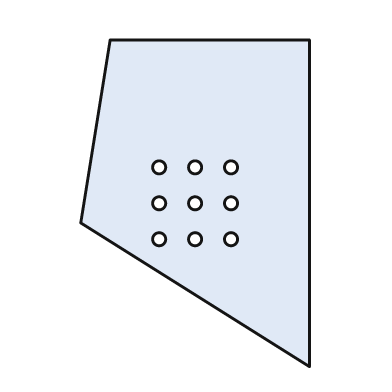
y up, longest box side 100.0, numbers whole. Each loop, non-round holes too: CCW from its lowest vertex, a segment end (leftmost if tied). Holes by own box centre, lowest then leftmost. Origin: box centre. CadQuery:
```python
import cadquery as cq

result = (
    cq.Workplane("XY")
    .moveTo(35.0, -50.0)
    .lineTo(35.0, 50.0)
    .lineTo(-26.0, 50.0)
    .lineTo(-35.0, -6.0)
    .close()
    .moveTo(-11.0, -11.0)
    .circle(2.0)
    .moveTo(0.0, -11.0)
    .circle(2.0)
    .moveTo(11.0, -11.0)
    .circle(2.0)
    .moveTo(-11.0, 0.0)
    .circle(2.0)
    .moveTo(0.0, 0.0)
    .circle(2.0)
    .moveTo(11.0, 0.0)
    .circle(2.0)
    .moveTo(-11.0, 11.0)
    .circle(2.0)
    .moveTo(0.0, 11.0)
    .circle(2.0)
    .moveTo(11.0, 11.0)
    .circle(2.0)
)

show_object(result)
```